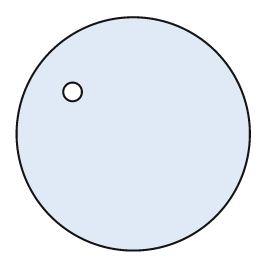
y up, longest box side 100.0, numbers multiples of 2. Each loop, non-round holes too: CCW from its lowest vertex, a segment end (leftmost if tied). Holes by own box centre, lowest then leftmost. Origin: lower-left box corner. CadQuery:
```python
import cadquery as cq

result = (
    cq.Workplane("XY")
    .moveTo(50.0, 50.0)
    .circle(50.0)
    .moveTo(24.0, 68.0)
    .circle(4.0)
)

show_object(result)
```